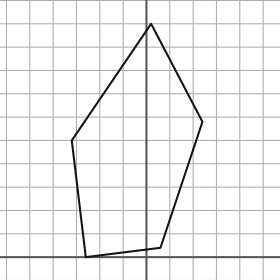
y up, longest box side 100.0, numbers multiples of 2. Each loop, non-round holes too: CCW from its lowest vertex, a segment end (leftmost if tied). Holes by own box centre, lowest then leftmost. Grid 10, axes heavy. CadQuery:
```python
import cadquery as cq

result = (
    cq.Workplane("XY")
    .moveTo(-26.0, 0.0)
    .lineTo(6.0, 4.0)
    .lineTo(24.0, 58.0)
    .lineTo(2.0, 100.0)
    .lineTo(-32.0, 50.0)
    .close()
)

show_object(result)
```